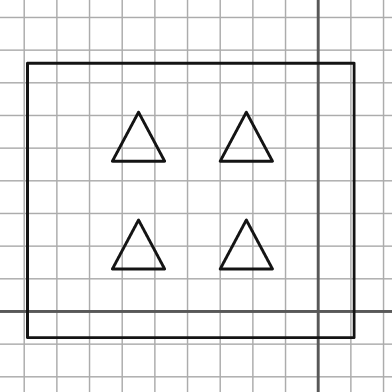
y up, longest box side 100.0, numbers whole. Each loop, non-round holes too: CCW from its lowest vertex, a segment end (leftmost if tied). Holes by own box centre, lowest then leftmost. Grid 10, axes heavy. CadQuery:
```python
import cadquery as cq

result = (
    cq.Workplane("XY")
    .moveTo(-89.0, -8.0)
    .lineTo(11.0, -8.0)
    .lineTo(11.0, 76.0)
    .lineTo(-89.0, 76.0)
    .close()
    .moveTo(-63.0, 13.0)
    .lineTo(-47.0, 13.0)
    .lineTo(-55.0, 28.0)
    .close()
    .moveTo(-30.0, 13.0)
    .lineTo(-14.0, 13.0)
    .lineTo(-22.0, 28.0)
    .close()
    .moveTo(-63.0, 46.0)
    .lineTo(-47.0, 46.0)
    .lineTo(-55.0, 61.0)
    .close()
    .moveTo(-30.0, 46.0)
    .lineTo(-14.0, 46.0)
    .lineTo(-22.0, 61.0)
    .close()
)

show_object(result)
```